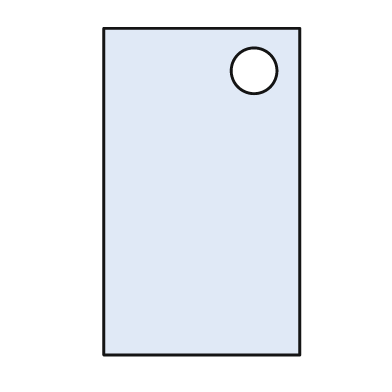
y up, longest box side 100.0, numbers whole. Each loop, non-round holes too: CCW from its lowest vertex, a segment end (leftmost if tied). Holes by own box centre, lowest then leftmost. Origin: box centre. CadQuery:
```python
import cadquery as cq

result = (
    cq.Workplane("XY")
    .moveTo(-30.0, -50.0)
    .lineTo(30.0, -50.0)
    .lineTo(30.0, 50.0)
    .lineTo(-30.0, 50.0)
    .close()
    .moveTo(16.0, 37.0)
    .circle(7.0)
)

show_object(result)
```